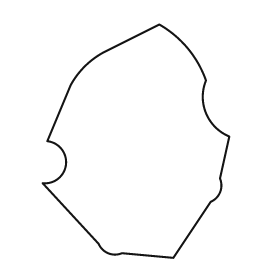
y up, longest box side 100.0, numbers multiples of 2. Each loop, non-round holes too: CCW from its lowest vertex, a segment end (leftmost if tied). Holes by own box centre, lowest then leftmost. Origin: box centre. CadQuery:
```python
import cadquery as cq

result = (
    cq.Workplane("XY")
    .moveTo(16.0, -50.0)
    .lineTo(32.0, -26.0)
    .threePointArc((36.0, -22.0), (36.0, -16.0))
    .lineTo(40.0, 2.0)
    .threePointArc((30.0, 12.0), (30.0, 26.0))
    .threePointArc((22.0, 40.0), (10.0, 50.0))
    .lineTo(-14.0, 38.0)
    .threePointArc((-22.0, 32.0), (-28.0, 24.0))
    .lineTo(-38.0, 0.0)
    .threePointArc((-30.0, -10.0), (-40.0, -18.0))
    .lineTo(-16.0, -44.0)
    .threePointArc((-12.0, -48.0), (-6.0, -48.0))
    .close()
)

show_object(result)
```